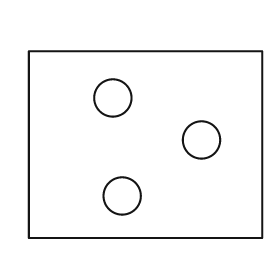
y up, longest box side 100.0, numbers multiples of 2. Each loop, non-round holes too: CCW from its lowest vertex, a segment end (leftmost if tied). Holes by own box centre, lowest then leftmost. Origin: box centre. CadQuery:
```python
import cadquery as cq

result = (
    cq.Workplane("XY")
    .moveTo(-50.0, -40.0)
    .lineTo(50.0, -40.0)
    .lineTo(50.0, 40.0)
    .lineTo(-50.0, 40.0)
    .close()
    .moveTo(-10.0, -22.0)
    .circle(8.0)
    .moveTo(24.0, 2.0)
    .circle(8.0)
    .moveTo(-14.0, 20.0)
    .circle(8.0)
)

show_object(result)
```